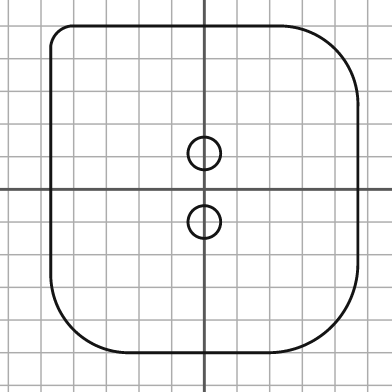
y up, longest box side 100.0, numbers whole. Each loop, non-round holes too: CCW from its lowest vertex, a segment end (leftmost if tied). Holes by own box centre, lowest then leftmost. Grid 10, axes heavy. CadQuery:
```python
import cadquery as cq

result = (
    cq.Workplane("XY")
    .moveTo(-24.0, -50.0)
    .lineTo(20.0, -50.0)
    .threePointArc((39.0, -42.0), (47.0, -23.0))
    .lineTo(47.0, 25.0)
    .threePointArc((40.0, 43.0), (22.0, 50.0))
    .lineTo(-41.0, 50.0)
    .threePointArc((-45.0, 48.0), (-47.0, 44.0))
    .lineTo(-47.0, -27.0)
    .threePointArc((-40.0, -43.0), (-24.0, -50.0))
    .close()
    .moveTo(0.0, -10.0)
    .circle(5.0)
    .moveTo(0.0, 11.0)
    .circle(5.0)
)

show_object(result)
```